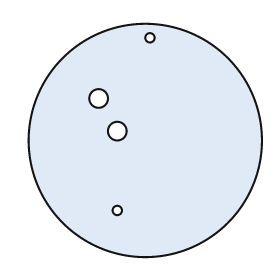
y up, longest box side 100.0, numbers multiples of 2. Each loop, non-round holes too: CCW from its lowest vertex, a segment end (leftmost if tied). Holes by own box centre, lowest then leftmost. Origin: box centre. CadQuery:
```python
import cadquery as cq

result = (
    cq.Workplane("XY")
    .moveTo(0.0, 0.0)
    .circle(50.0)
    .moveTo(-12.0, -30.0)
    .circle(2.0)
    .moveTo(-12.0, 4.0)
    .circle(4.0)
    .moveTo(-20.0, 18.0)
    .circle(4.0)
    .moveTo(2.0, 44.0)
    .circle(2.0)
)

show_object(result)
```